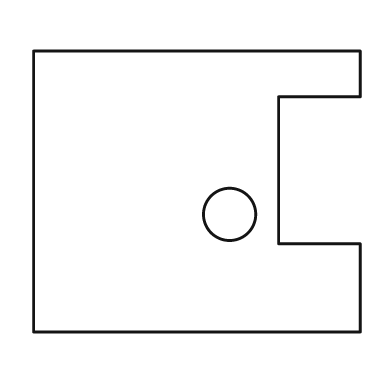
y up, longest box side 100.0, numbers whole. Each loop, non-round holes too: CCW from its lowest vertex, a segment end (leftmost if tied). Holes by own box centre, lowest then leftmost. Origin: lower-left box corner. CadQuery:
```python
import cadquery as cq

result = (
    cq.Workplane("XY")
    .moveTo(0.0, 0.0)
    .lineTo(100.0, 0.0)
    .lineTo(100.0, 27.0)
    .lineTo(75.0, 27.0)
    .lineTo(75.0, 72.0)
    .lineTo(100.0, 72.0)
    .lineTo(100.0, 86.0)
    .lineTo(0.0, 86.0)
    .close()
    .moveTo(60.0, 36.0)
    .circle(8.0)
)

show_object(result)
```